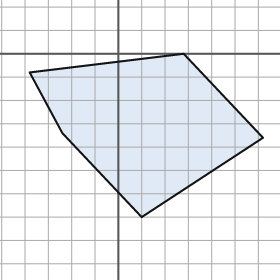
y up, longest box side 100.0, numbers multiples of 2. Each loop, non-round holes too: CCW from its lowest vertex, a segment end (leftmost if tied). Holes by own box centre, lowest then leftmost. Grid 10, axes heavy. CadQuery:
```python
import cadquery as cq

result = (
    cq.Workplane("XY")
    .moveTo(10.0, -70.0)
    .lineTo(62.0, -36.0)
    .lineTo(28.0, 0.0)
    .lineTo(-38.0, -8.0)
    .lineTo(-24.0, -34.0)
    .close()
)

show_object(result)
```